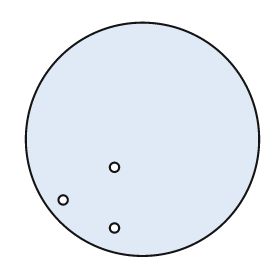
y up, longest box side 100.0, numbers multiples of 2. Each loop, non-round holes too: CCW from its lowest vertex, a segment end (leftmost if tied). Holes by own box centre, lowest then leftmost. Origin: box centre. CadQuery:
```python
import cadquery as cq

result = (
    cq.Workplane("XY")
    .moveTo(0.0, 0.0)
    .circle(50.0)
    .moveTo(-12.0, -38.0)
    .circle(2.0)
    .moveTo(-34.0, -26.0)
    .circle(2.0)
    .moveTo(-12.0, -12.0)
    .circle(2.0)
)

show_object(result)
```